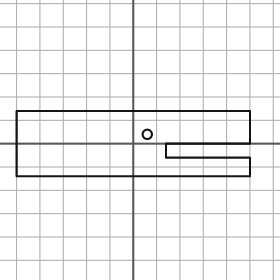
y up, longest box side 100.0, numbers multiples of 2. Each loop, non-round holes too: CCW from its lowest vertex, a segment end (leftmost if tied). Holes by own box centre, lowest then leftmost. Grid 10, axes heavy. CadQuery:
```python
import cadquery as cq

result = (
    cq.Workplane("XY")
    .moveTo(-50.0, -14.0)
    .lineTo(50.0, -14.0)
    .lineTo(50.0, -6.0)
    .lineTo(14.0, -6.0)
    .lineTo(14.0, 0.0)
    .lineTo(50.0, 0.0)
    .lineTo(50.0, 14.0)
    .lineTo(-50.0, 14.0)
    .close()
    .moveTo(6.0, 4.0)
    .circle(2.0)
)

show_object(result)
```